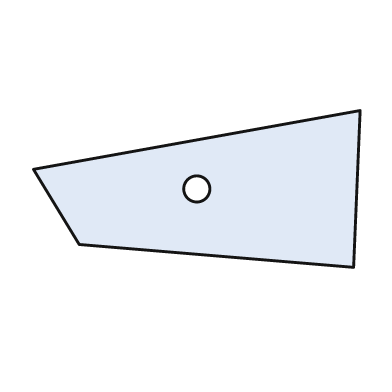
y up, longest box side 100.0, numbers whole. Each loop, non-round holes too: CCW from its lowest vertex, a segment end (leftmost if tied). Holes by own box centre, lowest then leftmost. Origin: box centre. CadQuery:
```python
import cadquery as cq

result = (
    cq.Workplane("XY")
    .moveTo(48.0, -24.0)
    .lineTo(50.0, 24.0)
    .lineTo(-50.0, 6.0)
    .lineTo(-36.0, -17.0)
    .close()
    .moveTo(0.0, 0.0)
    .circle(4.0)
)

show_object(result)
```